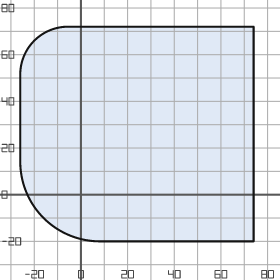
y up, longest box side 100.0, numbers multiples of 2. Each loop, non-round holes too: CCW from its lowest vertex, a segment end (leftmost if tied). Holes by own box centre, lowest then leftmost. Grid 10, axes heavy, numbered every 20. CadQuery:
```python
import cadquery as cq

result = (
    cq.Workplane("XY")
    .moveTo(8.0, -20.0)
    .lineTo(74.0, -20.0)
    .lineTo(74.0, 72.0)
    .lineTo(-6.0, 72.0)
    .threePointArc((-20.0, 66.0), (-26.0, 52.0))
    .lineTo(-26.0, 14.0)
    .threePointArc((-16.0, -10.0), (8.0, -20.0))
    .close()
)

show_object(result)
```